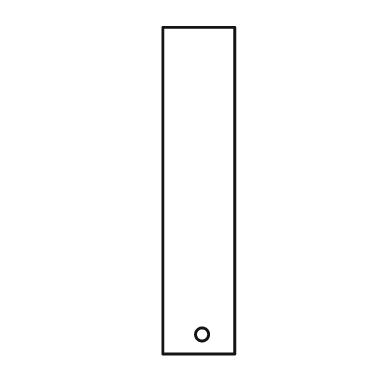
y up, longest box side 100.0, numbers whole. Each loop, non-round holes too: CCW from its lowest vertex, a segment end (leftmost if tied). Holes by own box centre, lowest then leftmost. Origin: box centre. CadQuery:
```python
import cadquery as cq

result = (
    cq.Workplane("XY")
    .moveTo(-11.0, -50.0)
    .lineTo(11.0, -50.0)
    .lineTo(11.0, 50.0)
    .lineTo(-11.0, 50.0)
    .close()
    .moveTo(1.0, -44.0)
    .circle(2.0)
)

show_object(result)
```